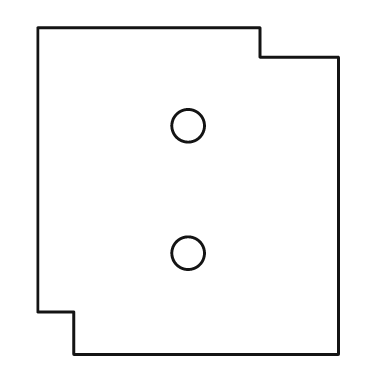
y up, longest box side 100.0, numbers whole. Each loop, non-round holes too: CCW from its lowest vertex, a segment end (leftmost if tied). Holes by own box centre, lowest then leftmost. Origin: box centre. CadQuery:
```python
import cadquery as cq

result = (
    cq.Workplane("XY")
    .moveTo(-35.0, -50.0)
    .lineTo(46.0, -50.0)
    .lineTo(46.0, 41.0)
    .lineTo(22.0, 41.0)
    .lineTo(22.0, 50.0)
    .lineTo(-46.0, 50.0)
    .lineTo(-46.0, -37.0)
    .lineTo(-35.0, -37.0)
    .close()
    .moveTo(0.0, -19.0)
    .circle(5.0)
    .moveTo(0.0, 20.0)
    .circle(5.0)
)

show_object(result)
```